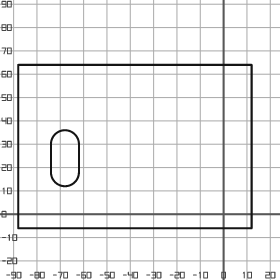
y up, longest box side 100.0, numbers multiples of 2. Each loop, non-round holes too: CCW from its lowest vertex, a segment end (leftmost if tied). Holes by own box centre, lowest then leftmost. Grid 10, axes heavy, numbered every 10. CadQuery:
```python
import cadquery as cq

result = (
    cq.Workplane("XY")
    .moveTo(-88.0, -6.0)
    .lineTo(12.0, -6.0)
    .lineTo(12.0, 64.0)
    .lineTo(-88.0, 64.0)
    .close()
    .moveTo(-74.0, 18.0)
    .threePointArc((-68.0, 12.0), (-62.0, 18.0))
    .lineTo(-62.0, 30.0)
    .threePointArc((-68.0, 36.0), (-74.0, 30.0))
    .close()
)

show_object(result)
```